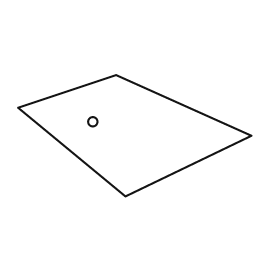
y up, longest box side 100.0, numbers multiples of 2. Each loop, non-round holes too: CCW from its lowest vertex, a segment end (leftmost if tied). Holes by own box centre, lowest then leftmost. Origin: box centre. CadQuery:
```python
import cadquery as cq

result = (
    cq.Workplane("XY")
    .moveTo(-4.0, -26.0)
    .lineTo(50.0, 0.0)
    .lineTo(-8.0, 26.0)
    .lineTo(-50.0, 12.0)
    .close()
    .moveTo(-18.0, 6.0)
    .circle(2.0)
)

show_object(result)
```